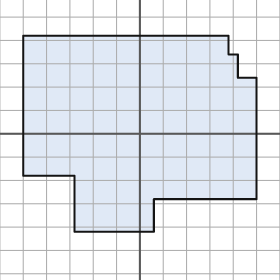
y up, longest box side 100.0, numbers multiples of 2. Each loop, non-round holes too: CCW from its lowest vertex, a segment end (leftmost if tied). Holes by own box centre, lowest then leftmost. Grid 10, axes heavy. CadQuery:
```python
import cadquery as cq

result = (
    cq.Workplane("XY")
    .moveTo(-28.0, -42.0)
    .lineTo(6.0, -42.0)
    .lineTo(6.0, -28.0)
    .lineTo(50.0, -28.0)
    .lineTo(50.0, 24.0)
    .lineTo(42.0, 24.0)
    .lineTo(42.0, 34.0)
    .lineTo(38.0, 34.0)
    .lineTo(38.0, 42.0)
    .lineTo(-50.0, 42.0)
    .lineTo(-50.0, -18.0)
    .lineTo(-28.0, -18.0)
    .close()
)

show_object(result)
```